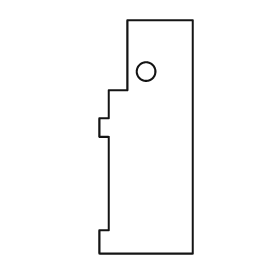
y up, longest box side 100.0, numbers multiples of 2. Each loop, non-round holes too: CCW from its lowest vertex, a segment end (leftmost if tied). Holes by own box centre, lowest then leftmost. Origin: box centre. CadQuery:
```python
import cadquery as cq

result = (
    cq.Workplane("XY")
    .moveTo(-20.0, -50.0)
    .lineTo(20.0, -50.0)
    .lineTo(20.0, 50.0)
    .lineTo(-8.0, 50.0)
    .lineTo(-8.0, 20.0)
    .lineTo(-16.0, 20.0)
    .lineTo(-16.0, 8.0)
    .lineTo(-20.0, 8.0)
    .lineTo(-20.0, 0.0)
    .lineTo(-16.0, 0.0)
    .lineTo(-16.0, -40.0)
    .lineTo(-20.0, -40.0)
    .close()
    .moveTo(0.0, 28.0)
    .circle(4.0)
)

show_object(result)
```